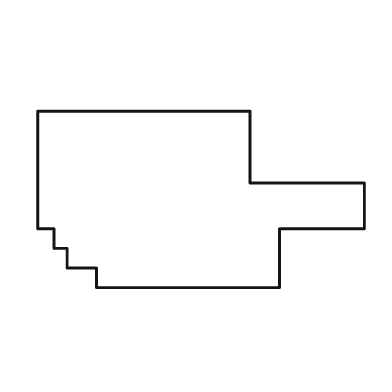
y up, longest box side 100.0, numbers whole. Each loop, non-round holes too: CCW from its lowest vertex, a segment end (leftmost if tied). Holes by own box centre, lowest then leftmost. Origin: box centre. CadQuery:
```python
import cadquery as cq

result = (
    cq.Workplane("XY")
    .moveTo(-32.0, -27.0)
    .lineTo(24.0, -27.0)
    .lineTo(24.0, -9.0)
    .lineTo(50.0, -9.0)
    .lineTo(50.0, 5.0)
    .lineTo(15.0, 5.0)
    .lineTo(15.0, 27.0)
    .lineTo(-50.0, 27.0)
    .lineTo(-50.0, -9.0)
    .lineTo(-45.0, -9.0)
    .lineTo(-45.0, -15.0)
    .lineTo(-41.0, -15.0)
    .lineTo(-41.0, -21.0)
    .lineTo(-32.0, -21.0)
    .close()
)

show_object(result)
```